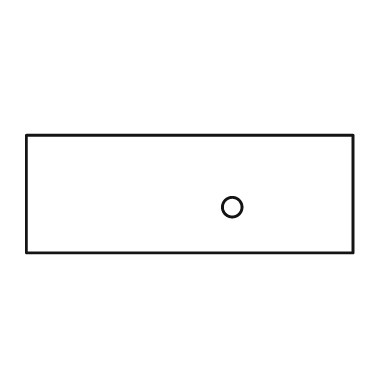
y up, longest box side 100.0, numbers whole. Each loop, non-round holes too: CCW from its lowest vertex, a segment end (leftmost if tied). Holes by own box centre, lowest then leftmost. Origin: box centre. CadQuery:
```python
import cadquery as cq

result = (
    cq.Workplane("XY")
    .moveTo(-50.0, -18.0)
    .lineTo(50.0, -18.0)
    .lineTo(50.0, 18.0)
    .lineTo(-50.0, 18.0)
    .close()
    .moveTo(13.0, -4.0)
    .circle(3.0)
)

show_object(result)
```